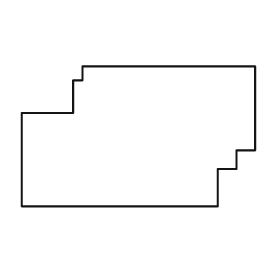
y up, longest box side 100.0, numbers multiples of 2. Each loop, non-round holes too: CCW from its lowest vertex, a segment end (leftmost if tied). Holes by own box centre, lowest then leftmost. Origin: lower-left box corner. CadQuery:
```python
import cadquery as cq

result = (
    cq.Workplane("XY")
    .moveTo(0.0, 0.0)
    .lineTo(84.0, 0.0)
    .lineTo(84.0, 16.0)
    .lineTo(92.0, 16.0)
    .lineTo(92.0, 24.0)
    .lineTo(100.0, 24.0)
    .lineTo(100.0, 60.0)
    .lineTo(26.0, 60.0)
    .lineTo(26.0, 54.0)
    .lineTo(22.0, 54.0)
    .lineTo(22.0, 40.0)
    .lineTo(0.0, 40.0)
    .close()
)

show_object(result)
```